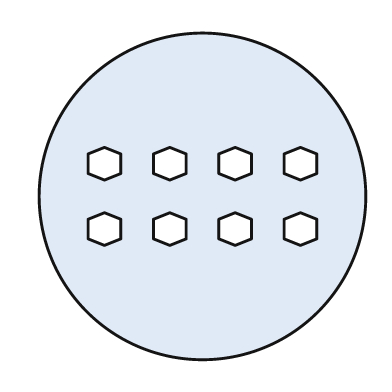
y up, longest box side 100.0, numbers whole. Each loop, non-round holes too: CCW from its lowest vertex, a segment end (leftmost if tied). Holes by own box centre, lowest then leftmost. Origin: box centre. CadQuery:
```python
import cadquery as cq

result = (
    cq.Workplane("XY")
    .moveTo(0.0, 0.0)
    .circle(50.0)
    .moveTo(-30.0, -15.0)
    .lineTo(-25.0, -13.0)
    .lineTo(-25.0, -7.0)
    .lineTo(-30.0, -5.0)
    .lineTo(-35.0, -7.0)
    .lineTo(-35.0, -13.0)
    .close()
    .moveTo(-10.0, -15.0)
    .lineTo(-5.0, -13.0)
    .lineTo(-5.0, -7.0)
    .lineTo(-10.0, -5.0)
    .lineTo(-15.0, -7.0)
    .lineTo(-15.0, -13.0)
    .close()
    .moveTo(10.0, -15.0)
    .lineTo(15.0, -13.0)
    .lineTo(15.0, -7.0)
    .lineTo(10.0, -5.0)
    .lineTo(5.0, -7.0)
    .lineTo(5.0, -13.0)
    .close()
    .moveTo(30.0, -15.0)
    .lineTo(35.0, -13.0)
    .lineTo(35.0, -7.0)
    .lineTo(30.0, -5.0)
    .lineTo(25.0, -7.0)
    .lineTo(25.0, -13.0)
    .close()
    .moveTo(-30.0, 5.0)
    .lineTo(-25.0, 7.0)
    .lineTo(-25.0, 13.0)
    .lineTo(-30.0, 15.0)
    .lineTo(-35.0, 13.0)
    .lineTo(-35.0, 7.0)
    .close()
    .moveTo(-10.0, 5.0)
    .lineTo(-5.0, 7.0)
    .lineTo(-5.0, 13.0)
    .lineTo(-10.0, 15.0)
    .lineTo(-15.0, 13.0)
    .lineTo(-15.0, 7.0)
    .close()
    .moveTo(10.0, 5.0)
    .lineTo(15.0, 7.0)
    .lineTo(15.0, 13.0)
    .lineTo(10.0, 15.0)
    .lineTo(5.0, 13.0)
    .lineTo(5.0, 7.0)
    .close()
    .moveTo(30.0, 5.0)
    .lineTo(35.0, 7.0)
    .lineTo(35.0, 13.0)
    .lineTo(30.0, 15.0)
    .lineTo(25.0, 13.0)
    .lineTo(25.0, 7.0)
    .close()
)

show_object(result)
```